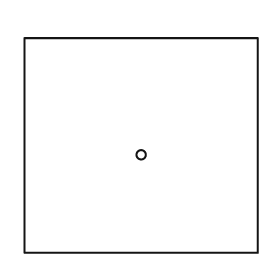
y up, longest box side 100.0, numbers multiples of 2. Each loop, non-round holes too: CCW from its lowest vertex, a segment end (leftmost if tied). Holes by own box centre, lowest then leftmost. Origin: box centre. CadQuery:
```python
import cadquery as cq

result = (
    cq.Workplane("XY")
    .moveTo(-50.0, -46.0)
    .lineTo(50.0, -46.0)
    .lineTo(50.0, 46.0)
    .lineTo(-50.0, 46.0)
    .close()
    .moveTo(0.0, -4.0)
    .circle(2.0)
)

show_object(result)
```